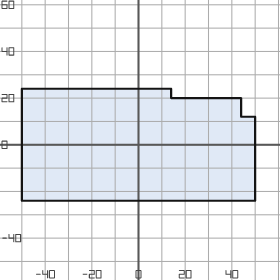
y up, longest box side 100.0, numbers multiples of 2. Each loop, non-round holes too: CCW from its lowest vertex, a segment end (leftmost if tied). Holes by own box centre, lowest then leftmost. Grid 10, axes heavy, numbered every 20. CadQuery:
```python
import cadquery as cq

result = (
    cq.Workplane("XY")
    .moveTo(-50.0, -24.0)
    .lineTo(50.0, -24.0)
    .lineTo(50.0, 12.0)
    .lineTo(44.0, 12.0)
    .lineTo(44.0, 20.0)
    .lineTo(14.0, 20.0)
    .lineTo(14.0, 24.0)
    .lineTo(-50.0, 24.0)
    .close()
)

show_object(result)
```